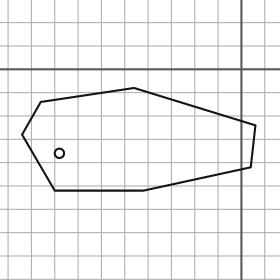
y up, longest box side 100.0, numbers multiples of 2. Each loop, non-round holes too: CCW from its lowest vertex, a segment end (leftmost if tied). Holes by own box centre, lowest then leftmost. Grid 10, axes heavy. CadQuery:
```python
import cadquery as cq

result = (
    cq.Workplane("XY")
    .moveTo(-80.0, -52.0)
    .lineTo(-42.0, -52.0)
    .lineTo(4.0, -42.0)
    .lineTo(6.0, -24.0)
    .lineTo(-46.0, -8.0)
    .lineTo(-86.0, -14.0)
    .lineTo(-94.0, -28.0)
    .close()
    .moveTo(-78.0, -36.0)
    .circle(2.0)
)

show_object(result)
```